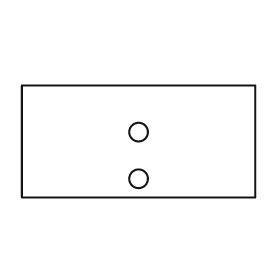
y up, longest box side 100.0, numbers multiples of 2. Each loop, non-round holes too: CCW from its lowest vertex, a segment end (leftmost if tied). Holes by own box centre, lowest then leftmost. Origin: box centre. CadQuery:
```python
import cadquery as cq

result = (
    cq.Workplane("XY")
    .moveTo(-50.0, -24.0)
    .lineTo(50.0, -24.0)
    .lineTo(50.0, 24.0)
    .lineTo(-50.0, 24.0)
    .close()
    .moveTo(0.0, -16.0)
    .circle(4.0)
    .moveTo(0.0, 4.0)
    .circle(4.0)
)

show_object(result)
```